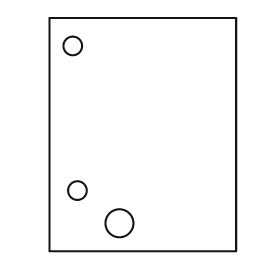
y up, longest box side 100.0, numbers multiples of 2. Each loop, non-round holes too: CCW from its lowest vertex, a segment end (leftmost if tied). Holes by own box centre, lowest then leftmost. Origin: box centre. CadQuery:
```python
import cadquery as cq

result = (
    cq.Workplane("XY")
    .moveTo(-40.0, -50.0)
    .lineTo(40.0, -50.0)
    .lineTo(40.0, 50.0)
    .lineTo(-40.0, 50.0)
    .close()
    .moveTo(-10.0, -38.0)
    .circle(6.0)
    .moveTo(-28.0, -24.0)
    .circle(4.0)
    .moveTo(-30.0, 38.0)
    .circle(4.0)
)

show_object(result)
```